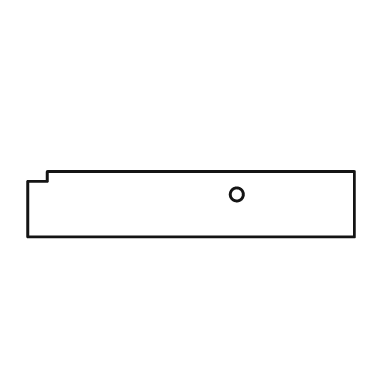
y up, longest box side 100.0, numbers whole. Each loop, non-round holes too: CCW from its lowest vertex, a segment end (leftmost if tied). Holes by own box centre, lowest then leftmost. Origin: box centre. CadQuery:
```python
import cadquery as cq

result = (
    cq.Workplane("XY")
    .moveTo(-50.0, -10.0)
    .lineTo(50.0, -10.0)
    .lineTo(50.0, 10.0)
    .lineTo(-44.0, 10.0)
    .lineTo(-44.0, 7.0)
    .lineTo(-50.0, 7.0)
    .close()
    .moveTo(14.0, 3.0)
    .circle(2.0)
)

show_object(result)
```